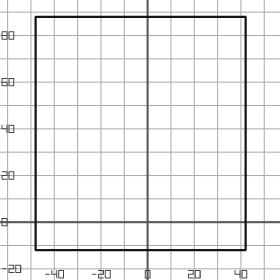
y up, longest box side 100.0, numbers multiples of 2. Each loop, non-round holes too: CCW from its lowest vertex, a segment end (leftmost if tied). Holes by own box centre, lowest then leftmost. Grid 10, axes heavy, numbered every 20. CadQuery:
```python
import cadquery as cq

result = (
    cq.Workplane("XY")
    .moveTo(-48.0, -12.0)
    .lineTo(42.0, -12.0)
    .lineTo(42.0, 88.0)
    .lineTo(-48.0, 88.0)
    .close()
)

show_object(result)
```